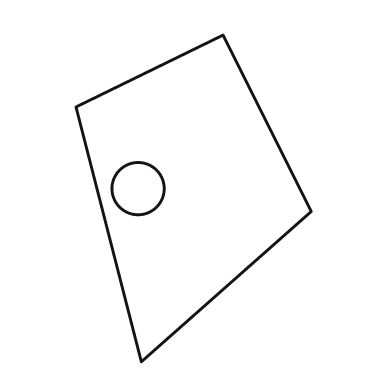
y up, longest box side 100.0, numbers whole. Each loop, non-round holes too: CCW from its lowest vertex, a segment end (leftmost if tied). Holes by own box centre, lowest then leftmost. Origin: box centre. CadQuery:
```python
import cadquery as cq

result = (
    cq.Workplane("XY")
    .moveTo(-16.0, -50.0)
    .lineTo(36.0, -4.0)
    .lineTo(9.0, 50.0)
    .lineTo(-36.0, 28.0)
    .close()
    .moveTo(-17.0, 3.0)
    .circle(8.0)
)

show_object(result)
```